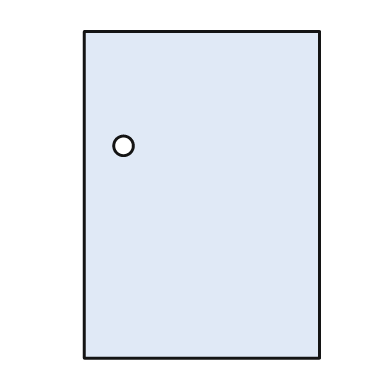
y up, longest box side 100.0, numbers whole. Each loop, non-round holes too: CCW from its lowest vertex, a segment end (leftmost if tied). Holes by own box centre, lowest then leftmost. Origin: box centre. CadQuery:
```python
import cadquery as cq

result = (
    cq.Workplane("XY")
    .moveTo(-36.0, -50.0)
    .lineTo(36.0, -50.0)
    .lineTo(36.0, 50.0)
    .lineTo(-36.0, 50.0)
    .close()
    .moveTo(-24.0, 15.0)
    .circle(3.0)
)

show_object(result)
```